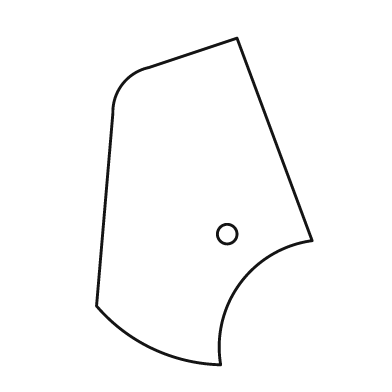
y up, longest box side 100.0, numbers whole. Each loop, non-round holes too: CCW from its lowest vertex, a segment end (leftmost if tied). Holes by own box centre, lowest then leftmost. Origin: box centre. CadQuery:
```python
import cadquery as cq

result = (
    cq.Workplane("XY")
    .moveTo(5.0, -50.0)
    .threePointArc((11.0, -25.0), (33.0, -12.0))
    .lineTo(10.0, 50.0)
    .lineTo(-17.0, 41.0)
    .threePointArc((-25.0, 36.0), (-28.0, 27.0))
    .lineTo(-33.0, -32.0)
    .threePointArc((-16.0, -45.0), (5.0, -50.0))
    .close()
    .moveTo(7.0, -10.0)
    .circle(3.0)
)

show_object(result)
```